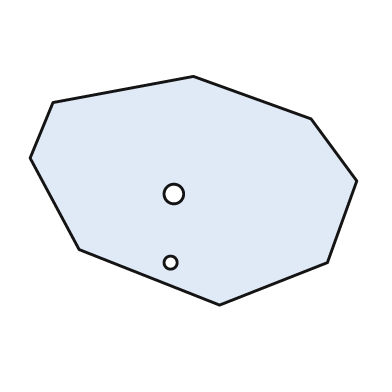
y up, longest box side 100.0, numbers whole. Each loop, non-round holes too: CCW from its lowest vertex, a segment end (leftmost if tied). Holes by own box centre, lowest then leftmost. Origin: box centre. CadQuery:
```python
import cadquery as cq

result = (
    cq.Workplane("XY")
    .moveTo(8.0, -35.0)
    .lineTo(41.0, -22.0)
    .lineTo(50.0, 3.0)
    .lineTo(36.0, 22.0)
    .lineTo(0.0, 35.0)
    .lineTo(-43.0, 27.0)
    .lineTo(-50.0, 10.0)
    .lineTo(-35.0, -18.0)
    .close()
    .moveTo(-7.0, -22.0)
    .circle(2.0)
    .moveTo(-6.0, -1.0)
    .circle(3.0)
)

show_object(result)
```